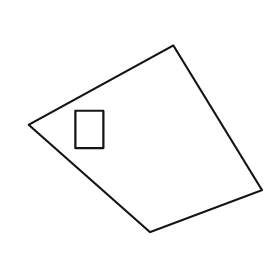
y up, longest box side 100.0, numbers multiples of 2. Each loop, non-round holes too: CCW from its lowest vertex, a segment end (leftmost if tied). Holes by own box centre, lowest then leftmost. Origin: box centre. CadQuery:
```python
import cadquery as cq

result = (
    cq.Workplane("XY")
    .moveTo(2.0, -40.0)
    .lineTo(50.0, -22.0)
    .lineTo(12.0, 40.0)
    .lineTo(-50.0, 6.0)
    .close()
    .moveTo(-30.0, -4.0)
    .lineTo(-18.0, -4.0)
    .lineTo(-18.0, 12.0)
    .lineTo(-30.0, 12.0)
    .close()
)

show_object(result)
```